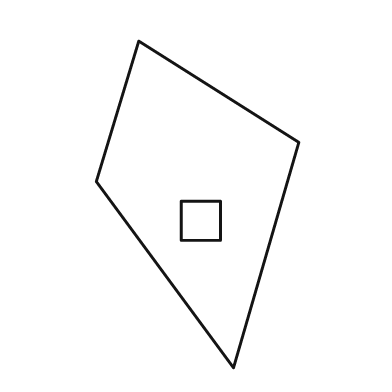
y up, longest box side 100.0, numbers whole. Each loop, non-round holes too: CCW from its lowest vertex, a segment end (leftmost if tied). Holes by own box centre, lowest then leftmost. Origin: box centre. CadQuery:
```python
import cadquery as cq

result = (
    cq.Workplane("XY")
    .moveTo(11.0, -50.0)
    .lineTo(31.0, 19.0)
    .lineTo(-18.0, 50.0)
    .lineTo(-31.0, 7.0)
    .close()
    .moveTo(-5.0, -11.0)
    .lineTo(7.0, -11.0)
    .lineTo(7.0, 1.0)
    .lineTo(-5.0, 1.0)
    .close()
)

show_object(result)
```